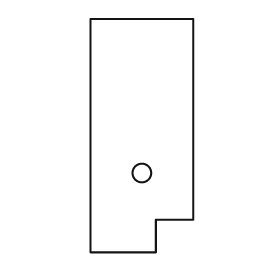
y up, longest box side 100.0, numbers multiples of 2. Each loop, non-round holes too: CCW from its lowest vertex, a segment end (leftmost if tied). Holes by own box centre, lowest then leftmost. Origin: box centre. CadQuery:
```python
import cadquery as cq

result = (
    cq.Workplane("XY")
    .moveTo(-22.0, -50.0)
    .lineTo(6.0, -50.0)
    .lineTo(6.0, -36.0)
    .lineTo(22.0, -36.0)
    .lineTo(22.0, 50.0)
    .lineTo(-22.0, 50.0)
    .close()
    .moveTo(0.0, -16.0)
    .circle(4.0)
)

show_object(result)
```